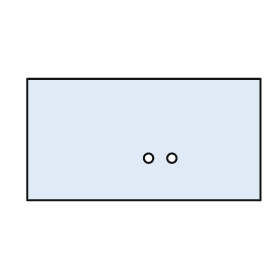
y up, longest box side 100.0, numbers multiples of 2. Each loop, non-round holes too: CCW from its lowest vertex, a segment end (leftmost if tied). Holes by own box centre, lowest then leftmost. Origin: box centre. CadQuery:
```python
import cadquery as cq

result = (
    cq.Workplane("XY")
    .moveTo(-50.0, -26.0)
    .lineTo(50.0, -26.0)
    .lineTo(50.0, 26.0)
    .lineTo(-50.0, 26.0)
    .close()
    .moveTo(2.0, -8.0)
    .circle(2.0)
    .moveTo(12.0, -8.0)
    .circle(2.0)
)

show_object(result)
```